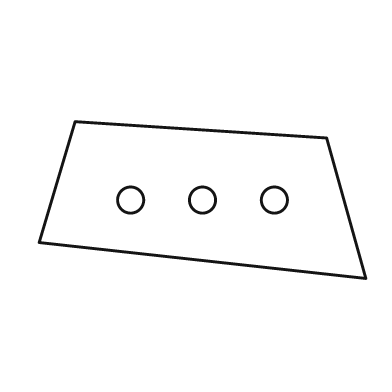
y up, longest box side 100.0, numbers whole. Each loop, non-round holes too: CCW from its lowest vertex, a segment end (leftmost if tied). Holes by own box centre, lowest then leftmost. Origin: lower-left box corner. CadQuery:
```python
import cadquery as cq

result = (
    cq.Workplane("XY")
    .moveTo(100.0, 0.0)
    .lineTo(88.0, 43.0)
    .lineTo(11.0, 48.0)
    .lineTo(0.0, 11.0)
    .close()
    .moveTo(28.0, 24.0)
    .circle(4.0)
    .moveTo(50.0, 24.0)
    .circle(4.0)
    .moveTo(72.0, 24.0)
    .circle(4.0)
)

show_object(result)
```